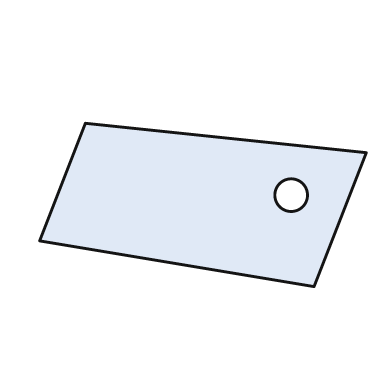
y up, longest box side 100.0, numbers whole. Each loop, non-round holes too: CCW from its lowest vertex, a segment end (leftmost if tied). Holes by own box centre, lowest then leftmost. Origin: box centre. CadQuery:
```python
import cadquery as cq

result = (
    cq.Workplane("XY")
    .moveTo(34.0, -25.0)
    .lineTo(50.0, 16.0)
    .lineTo(-36.0, 25.0)
    .lineTo(-50.0, -11.0)
    .close()
    .moveTo(27.0, 3.0)
    .circle(5.0)
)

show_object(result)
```